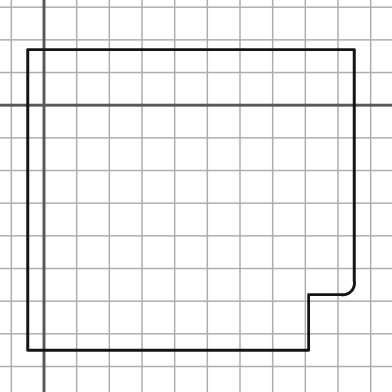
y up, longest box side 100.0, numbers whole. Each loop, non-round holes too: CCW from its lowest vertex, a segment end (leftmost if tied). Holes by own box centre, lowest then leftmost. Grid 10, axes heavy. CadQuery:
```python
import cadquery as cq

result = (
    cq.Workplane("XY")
    .moveTo(-5.0, -75.0)
    .lineTo(81.0, -75.0)
    .lineTo(81.0, -58.0)
    .lineTo(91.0, -58.0)
    .threePointArc((94.0, -57.0), (95.0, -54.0))
    .lineTo(95.0, 17.0)
    .lineTo(-5.0, 17.0)
    .close()
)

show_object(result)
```